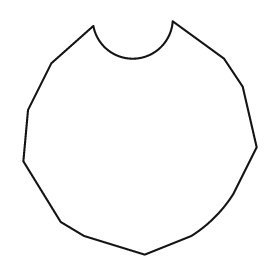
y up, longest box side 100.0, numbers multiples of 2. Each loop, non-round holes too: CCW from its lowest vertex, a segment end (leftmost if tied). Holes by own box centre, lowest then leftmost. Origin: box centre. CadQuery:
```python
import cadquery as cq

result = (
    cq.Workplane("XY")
    .moveTo(2.0, -50.0)
    .lineTo(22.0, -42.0)
    .threePointArc((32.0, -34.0), (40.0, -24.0))
    .lineTo(50.0, -4.0)
    .lineTo(44.0, 22.0)
    .lineTo(36.0, 34.0)
    .lineTo(14.0, 50.0)
    .threePointArc((-2.0, 34.0), (-20.0, 48.0))
    .lineTo(-38.0, 32.0)
    .lineTo(-48.0, 12.0)
    .lineTo(-50.0, -10.0)
    .lineTo(-34.0, -36.0)
    .lineTo(-24.0, -42.0)
    .close()
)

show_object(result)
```